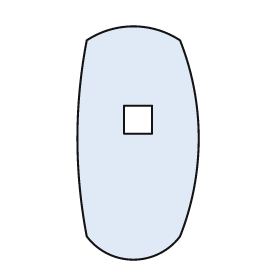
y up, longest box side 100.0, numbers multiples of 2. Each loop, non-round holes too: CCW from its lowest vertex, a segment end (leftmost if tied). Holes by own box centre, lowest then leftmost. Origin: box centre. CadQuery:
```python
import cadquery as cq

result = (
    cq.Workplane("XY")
    .moveTo(-22.0, -40.0)
    .threePointArc((-2.0, -50.0), (18.0, -40.0))
    .threePointArc((26.0, 2.0), (18.0, 44.0))
    .threePointArc((-2.0, 50.0), (-22.0, 44.0))
    .threePointArc((-26.0, 2.0), (-22.0, -40.0))
    .close()
    .moveTo(-6.0, 4.0)
    .lineTo(6.0, 4.0)
    .lineTo(6.0, 16.0)
    .lineTo(-6.0, 16.0)
    .close()
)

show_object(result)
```